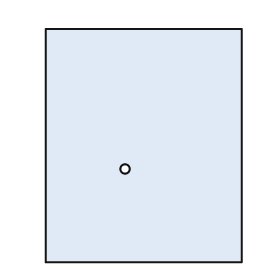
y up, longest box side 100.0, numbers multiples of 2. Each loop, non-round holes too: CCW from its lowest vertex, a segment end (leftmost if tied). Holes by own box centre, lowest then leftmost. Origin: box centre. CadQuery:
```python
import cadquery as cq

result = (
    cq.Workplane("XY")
    .moveTo(-42.0, -50.0)
    .lineTo(42.0, -50.0)
    .lineTo(42.0, 50.0)
    .lineTo(-42.0, 50.0)
    .close()
    .moveTo(-8.0, -10.0)
    .circle(2.0)
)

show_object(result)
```